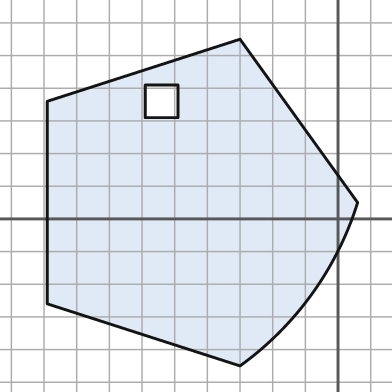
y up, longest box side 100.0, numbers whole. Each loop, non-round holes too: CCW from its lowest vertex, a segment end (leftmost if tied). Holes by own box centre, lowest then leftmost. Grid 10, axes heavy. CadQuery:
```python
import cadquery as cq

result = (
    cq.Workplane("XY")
    .moveTo(-30.0, -45.0)
    .threePointArc((-8.0, -23.0), (6.0, 5.0))
    .lineTo(-30.0, 55.0)
    .lineTo(-89.0, 36.0)
    .lineTo(-89.0, -26.0)
    .close()
    .moveTo(-59.0, 31.0)
    .lineTo(-49.0, 31.0)
    .lineTo(-49.0, 41.0)
    .lineTo(-59.0, 41.0)
    .close()
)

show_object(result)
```